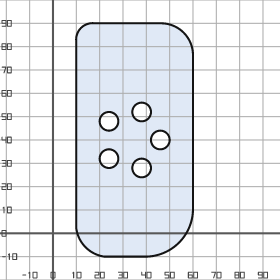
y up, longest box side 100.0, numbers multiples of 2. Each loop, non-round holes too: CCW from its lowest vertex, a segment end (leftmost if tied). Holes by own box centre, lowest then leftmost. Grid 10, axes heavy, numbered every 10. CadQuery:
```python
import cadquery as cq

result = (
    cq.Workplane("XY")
    .moveTo(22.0, -10.0)
    .lineTo(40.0, -10.0)
    .threePointArc((54.0, -4.0), (60.0, 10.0))
    .lineTo(60.0, 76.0)
    .threePointArc((56.0, 86.0), (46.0, 90.0))
    .lineTo(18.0, 90.0)
    .threePointArc((12.0, 88.0), (10.0, 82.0))
    .lineTo(10.0, 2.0)
    .threePointArc((14.0, -6.0), (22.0, -10.0))
    .close()
    .moveTo(38.0, 28.0)
    .circle(4.0)
    .moveTo(24.0, 32.0)
    .circle(4.0)
    .moveTo(46.0, 40.0)
    .circle(4.0)
    .moveTo(24.0, 48.0)
    .circle(4.0)
    .moveTo(38.0, 52.0)
    .circle(4.0)
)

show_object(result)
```